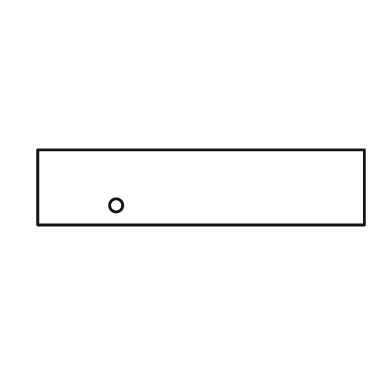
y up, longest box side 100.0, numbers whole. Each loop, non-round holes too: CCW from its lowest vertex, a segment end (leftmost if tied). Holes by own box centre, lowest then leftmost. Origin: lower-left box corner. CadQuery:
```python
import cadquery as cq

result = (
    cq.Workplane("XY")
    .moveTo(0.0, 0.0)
    .lineTo(100.0, 0.0)
    .lineTo(100.0, 23.0)
    .lineTo(0.0, 23.0)
    .close()
    .moveTo(24.0, 6.0)
    .circle(2.0)
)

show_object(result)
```